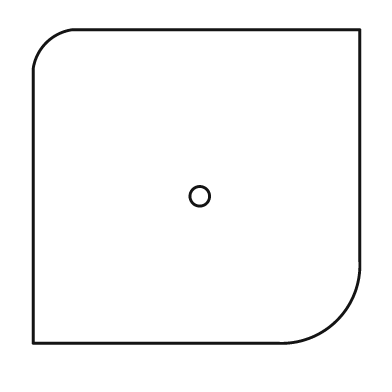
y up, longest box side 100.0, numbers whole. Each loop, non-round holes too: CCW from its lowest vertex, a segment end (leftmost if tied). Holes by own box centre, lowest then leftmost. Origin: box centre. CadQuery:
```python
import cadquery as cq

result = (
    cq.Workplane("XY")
    .moveTo(-50.0, -48.0)
    .lineTo(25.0, -48.0)
    .threePointArc((43.0, -41.0), (50.0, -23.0))
    .lineTo(50.0, 48.0)
    .lineTo(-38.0, 48.0)
    .threePointArc((-46.0, 44.0), (-50.0, 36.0))
    .close()
    .moveTo(1.0, -3.0)
    .circle(3.0)
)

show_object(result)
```